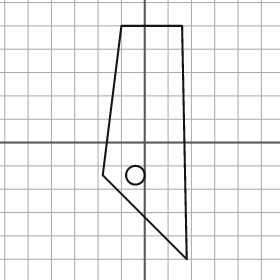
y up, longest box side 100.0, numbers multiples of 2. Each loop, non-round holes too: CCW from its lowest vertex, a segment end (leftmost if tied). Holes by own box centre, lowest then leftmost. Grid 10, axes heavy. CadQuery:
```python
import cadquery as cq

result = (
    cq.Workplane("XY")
    .moveTo(18.0, -50.0)
    .lineTo(16.0, 50.0)
    .lineTo(-10.0, 50.0)
    .lineTo(-18.0, -14.0)
    .close()
    .moveTo(-4.0, -14.0)
    .circle(4.0)
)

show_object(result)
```